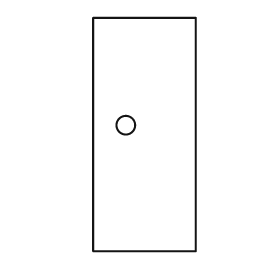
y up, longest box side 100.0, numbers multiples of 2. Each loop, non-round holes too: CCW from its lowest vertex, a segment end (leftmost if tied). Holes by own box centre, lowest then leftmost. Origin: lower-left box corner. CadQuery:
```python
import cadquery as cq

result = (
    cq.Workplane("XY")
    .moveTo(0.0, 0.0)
    .lineTo(44.0, 0.0)
    .lineTo(44.0, 100.0)
    .lineTo(0.0, 100.0)
    .close()
    .moveTo(14.0, 54.0)
    .circle(4.0)
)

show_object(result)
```